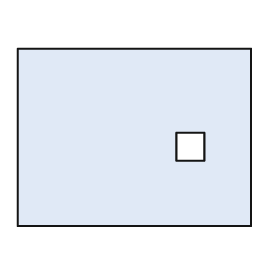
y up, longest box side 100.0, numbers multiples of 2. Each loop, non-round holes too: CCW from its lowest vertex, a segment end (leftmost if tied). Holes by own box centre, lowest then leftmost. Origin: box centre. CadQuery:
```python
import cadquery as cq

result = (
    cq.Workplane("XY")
    .moveTo(-50.0, -38.0)
    .lineTo(50.0, -38.0)
    .lineTo(50.0, 38.0)
    .lineTo(-50.0, 38.0)
    .close()
    .moveTo(18.0, -10.0)
    .lineTo(30.0, -10.0)
    .lineTo(30.0, 2.0)
    .lineTo(18.0, 2.0)
    .close()
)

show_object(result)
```